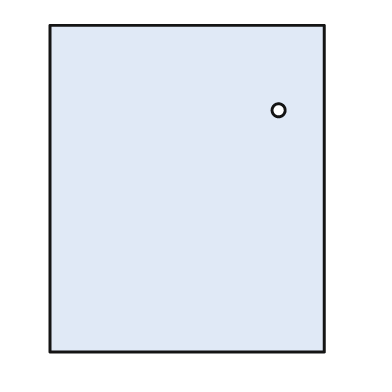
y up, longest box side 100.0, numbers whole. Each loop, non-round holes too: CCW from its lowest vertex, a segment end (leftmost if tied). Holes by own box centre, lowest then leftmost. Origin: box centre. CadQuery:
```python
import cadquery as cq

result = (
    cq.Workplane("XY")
    .moveTo(-42.0, -50.0)
    .lineTo(42.0, -50.0)
    .lineTo(42.0, 50.0)
    .lineTo(-42.0, 50.0)
    .close()
    .moveTo(28.0, 24.0)
    .circle(2.0)
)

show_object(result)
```